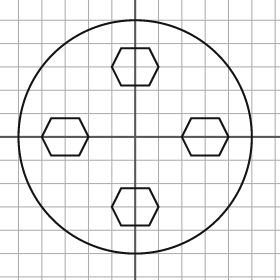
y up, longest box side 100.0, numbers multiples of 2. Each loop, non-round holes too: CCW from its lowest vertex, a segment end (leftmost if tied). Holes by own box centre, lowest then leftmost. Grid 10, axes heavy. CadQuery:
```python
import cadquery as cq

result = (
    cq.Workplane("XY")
    .moveTo(0.0, 0.0)
    .circle(50.0)
    .moveTo(-6.0, -38.0)
    .lineTo(6.0, -38.0)
    .lineTo(10.0, -30.0)
    .lineTo(6.0, -22.0)
    .lineTo(-6.0, -22.0)
    .lineTo(-10.0, -30.0)
    .close()
    .moveTo(-36.0, -8.0)
    .lineTo(-24.0, -8.0)
    .lineTo(-20.0, 0.0)
    .lineTo(-24.0, 8.0)
    .lineTo(-36.0, 8.0)
    .lineTo(-40.0, 0.0)
    .close()
    .moveTo(24.0, -8.0)
    .lineTo(36.0, -8.0)
    .lineTo(40.0, 0.0)
    .lineTo(36.0, 8.0)
    .lineTo(24.0, 8.0)
    .lineTo(20.0, 0.0)
    .close()
    .moveTo(-6.0, 22.0)
    .lineTo(6.0, 22.0)
    .lineTo(10.0, 30.0)
    .lineTo(6.0, 38.0)
    .lineTo(-6.0, 38.0)
    .lineTo(-10.0, 30.0)
    .close()
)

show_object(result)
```